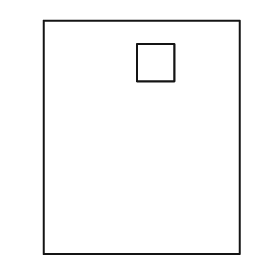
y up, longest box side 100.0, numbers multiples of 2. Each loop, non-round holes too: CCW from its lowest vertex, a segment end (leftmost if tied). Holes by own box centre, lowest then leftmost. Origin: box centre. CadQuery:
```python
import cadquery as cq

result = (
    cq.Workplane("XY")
    .moveTo(-42.0, -50.0)
    .lineTo(42.0, -50.0)
    .lineTo(42.0, 50.0)
    .lineTo(-42.0, 50.0)
    .close()
    .moveTo(-2.0, 24.0)
    .lineTo(14.0, 24.0)
    .lineTo(14.0, 40.0)
    .lineTo(-2.0, 40.0)
    .close()
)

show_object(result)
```